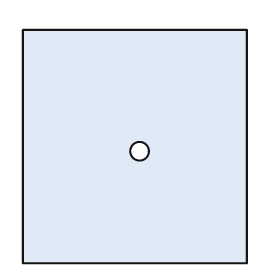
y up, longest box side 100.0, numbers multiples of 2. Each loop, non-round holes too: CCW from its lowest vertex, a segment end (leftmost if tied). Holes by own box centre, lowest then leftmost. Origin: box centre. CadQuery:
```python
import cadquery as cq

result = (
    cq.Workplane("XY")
    .moveTo(-48.0, -50.0)
    .lineTo(48.0, -50.0)
    .lineTo(48.0, 50.0)
    .lineTo(-48.0, 50.0)
    .close()
    .moveTo(2.0, -2.0)
    .circle(4.0)
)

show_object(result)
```